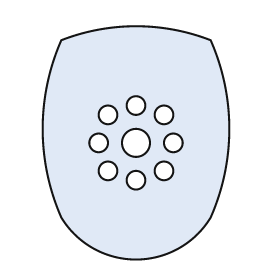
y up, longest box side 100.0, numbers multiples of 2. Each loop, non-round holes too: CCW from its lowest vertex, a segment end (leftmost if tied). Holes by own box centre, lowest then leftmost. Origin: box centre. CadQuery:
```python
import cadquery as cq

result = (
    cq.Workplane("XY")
    .moveTo(-32.0, -32.0)
    .threePointArc((0.0, -50.0), (32.0, -32.0))
    .threePointArc((40.0, 6.0), (32.0, 44.0))
    .threePointArc((0.0, 50.0), (-32.0, 44.0))
    .threePointArc((-40.0, 6.0), (-32.0, -32.0))
    .close()
    .moveTo(0.0, -16.0)
    .circle(4.0)
    .moveTo(-12.0, -12.0)
    .circle(4.0)
    .moveTo(12.0, -12.0)
    .circle(4.0)
    .moveTo(-16.0, 0.0)
    .circle(4.0)
    .moveTo(0.0, 0.0)
    .circle(6.0)
    .moveTo(16.0, 0.0)
    .circle(4.0)
    .moveTo(-12.0, 12.0)
    .circle(4.0)
    .moveTo(12.0, 12.0)
    .circle(4.0)
    .moveTo(0.0, 16.0)
    .circle(4.0)
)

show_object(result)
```